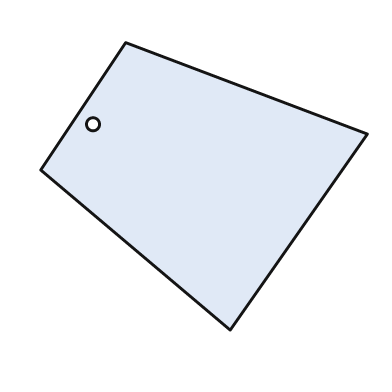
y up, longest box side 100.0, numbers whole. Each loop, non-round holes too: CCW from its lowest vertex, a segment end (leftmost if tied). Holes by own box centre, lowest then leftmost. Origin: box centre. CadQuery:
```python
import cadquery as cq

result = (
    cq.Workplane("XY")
    .moveTo(8.0, -44.0)
    .lineTo(50.0, 16.0)
    .lineTo(-24.0, 44.0)
    .lineTo(-50.0, 5.0)
    .close()
    .moveTo(-34.0, 19.0)
    .circle(2.0)
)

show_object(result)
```